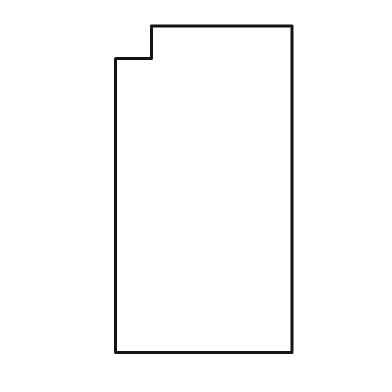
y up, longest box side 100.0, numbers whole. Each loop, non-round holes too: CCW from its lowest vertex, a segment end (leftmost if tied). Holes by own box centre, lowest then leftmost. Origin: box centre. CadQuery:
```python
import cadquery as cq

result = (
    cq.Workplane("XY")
    .moveTo(-27.0, -50.0)
    .lineTo(27.0, -50.0)
    .lineTo(27.0, 50.0)
    .lineTo(-16.0, 50.0)
    .lineTo(-16.0, 40.0)
    .lineTo(-27.0, 40.0)
    .close()
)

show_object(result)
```